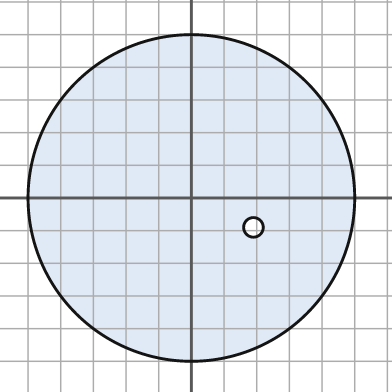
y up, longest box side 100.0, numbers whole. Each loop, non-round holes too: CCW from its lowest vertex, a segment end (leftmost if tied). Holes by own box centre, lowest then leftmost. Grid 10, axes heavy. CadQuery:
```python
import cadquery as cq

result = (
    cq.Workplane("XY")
    .moveTo(0.0, 0.0)
    .circle(50.0)
    .moveTo(19.0, -9.0)
    .circle(3.0)
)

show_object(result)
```